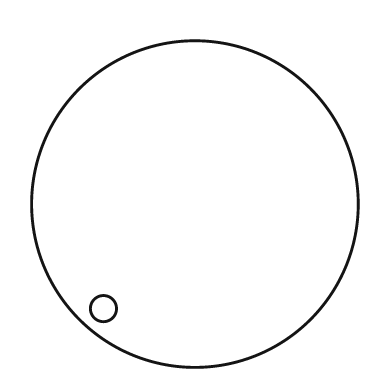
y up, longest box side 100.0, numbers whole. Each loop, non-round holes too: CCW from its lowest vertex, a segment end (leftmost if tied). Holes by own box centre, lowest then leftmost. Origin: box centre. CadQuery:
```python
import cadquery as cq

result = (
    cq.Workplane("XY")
    .moveTo(0.0, 0.0)
    .circle(50.0)
    .moveTo(-28.0, -32.0)
    .circle(4.0)
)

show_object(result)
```